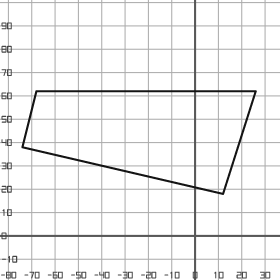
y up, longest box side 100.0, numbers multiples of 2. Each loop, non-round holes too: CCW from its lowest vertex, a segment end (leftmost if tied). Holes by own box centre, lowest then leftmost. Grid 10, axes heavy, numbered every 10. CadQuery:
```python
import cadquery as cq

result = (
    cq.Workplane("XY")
    .moveTo(12.0, 18.0)
    .lineTo(26.0, 62.0)
    .lineTo(-68.0, 62.0)
    .lineTo(-74.0, 38.0)
    .close()
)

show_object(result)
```